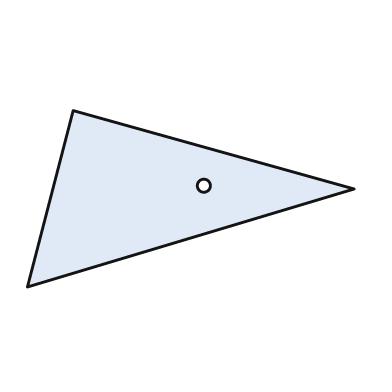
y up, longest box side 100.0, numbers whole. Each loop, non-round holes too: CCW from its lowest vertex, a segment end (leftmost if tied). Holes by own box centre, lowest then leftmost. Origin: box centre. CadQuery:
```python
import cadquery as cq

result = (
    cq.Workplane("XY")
    .moveTo(-50.0, -27.0)
    .lineTo(50.0, 3.0)
    .lineTo(-36.0, 27.0)
    .close()
    .moveTo(4.0, 4.0)
    .circle(2.0)
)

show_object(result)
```